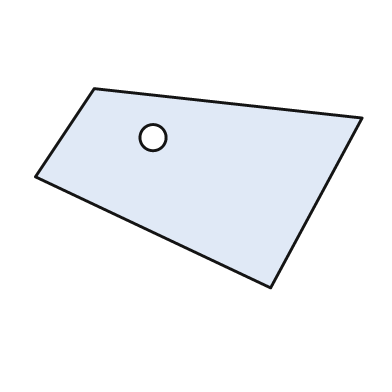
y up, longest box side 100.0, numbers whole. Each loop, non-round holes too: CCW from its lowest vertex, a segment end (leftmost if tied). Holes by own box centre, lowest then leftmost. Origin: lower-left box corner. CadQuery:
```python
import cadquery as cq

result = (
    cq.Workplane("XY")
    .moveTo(72.0, 0.0)
    .lineTo(100.0, 52.0)
    .lineTo(18.0, 61.0)
    .lineTo(0.0, 34.0)
    .close()
    .moveTo(36.0, 46.0)
    .circle(4.0)
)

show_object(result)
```